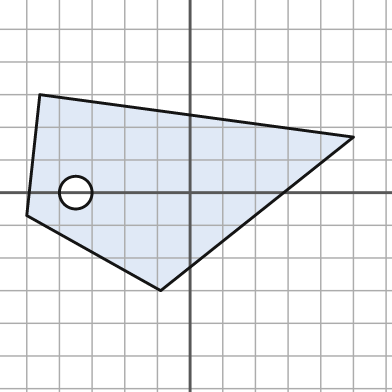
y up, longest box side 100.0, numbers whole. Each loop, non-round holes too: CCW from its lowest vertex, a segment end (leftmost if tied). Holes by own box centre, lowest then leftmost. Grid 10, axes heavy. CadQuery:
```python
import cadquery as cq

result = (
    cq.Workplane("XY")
    .moveTo(-9.0, -30.0)
    .lineTo(50.0, 17.0)
    .lineTo(-46.0, 30.0)
    .lineTo(-50.0, -7.0)
    .close()
    .moveTo(-35.0, 0.0)
    .circle(5.0)
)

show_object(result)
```